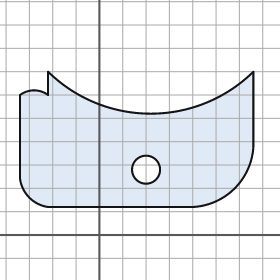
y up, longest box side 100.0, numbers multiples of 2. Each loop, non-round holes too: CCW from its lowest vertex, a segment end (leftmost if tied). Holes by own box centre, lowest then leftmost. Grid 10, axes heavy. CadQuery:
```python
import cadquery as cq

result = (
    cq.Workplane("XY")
    .moveTo(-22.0, 12.0)
    .lineTo(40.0, 12.0)
    .threePointArc((58.0, 20.0), (66.0, 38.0))
    .lineTo(66.0, 70.0)
    .threePointArc((22.0, 52.0), (-22.0, 70.0))
    .lineTo(-22.0, 60.0)
    .threePointArc((-28.0, 62.0), (-34.0, 60.0))
    .lineTo(-34.0, 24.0)
    .threePointArc((-30.0, 16.0), (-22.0, 12.0))
    .close()
    .moveTo(20.0, 28.0)
    .circle(6.0)
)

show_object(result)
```